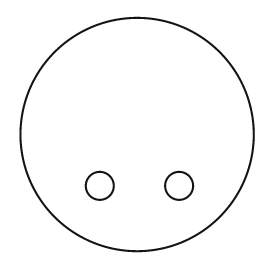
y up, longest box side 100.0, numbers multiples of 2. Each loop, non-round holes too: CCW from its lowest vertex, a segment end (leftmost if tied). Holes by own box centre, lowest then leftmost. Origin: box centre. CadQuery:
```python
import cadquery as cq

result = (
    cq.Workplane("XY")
    .moveTo(0.0, 0.0)
    .circle(50.0)
    .moveTo(-16.0, -22.0)
    .circle(6.0)
    .moveTo(18.0, -22.0)
    .circle(6.0)
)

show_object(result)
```